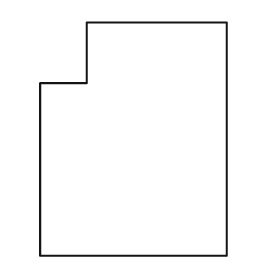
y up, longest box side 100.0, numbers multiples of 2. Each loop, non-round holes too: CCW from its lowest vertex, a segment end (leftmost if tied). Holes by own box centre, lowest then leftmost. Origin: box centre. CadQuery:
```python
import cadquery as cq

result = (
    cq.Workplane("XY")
    .moveTo(-40.0, -50.0)
    .lineTo(40.0, -50.0)
    .lineTo(40.0, 50.0)
    .lineTo(-20.0, 50.0)
    .lineTo(-20.0, 24.0)
    .lineTo(-40.0, 24.0)
    .close()
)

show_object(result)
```